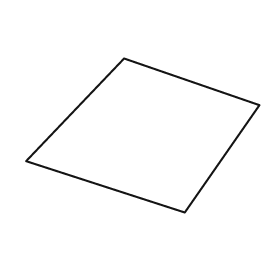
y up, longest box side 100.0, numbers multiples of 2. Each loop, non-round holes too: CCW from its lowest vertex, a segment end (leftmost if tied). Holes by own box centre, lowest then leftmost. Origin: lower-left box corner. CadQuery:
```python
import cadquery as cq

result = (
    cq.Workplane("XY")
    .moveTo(68.0, 0.0)
    .lineTo(100.0, 46.0)
    .lineTo(42.0, 66.0)
    .lineTo(0.0, 22.0)
    .close()
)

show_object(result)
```